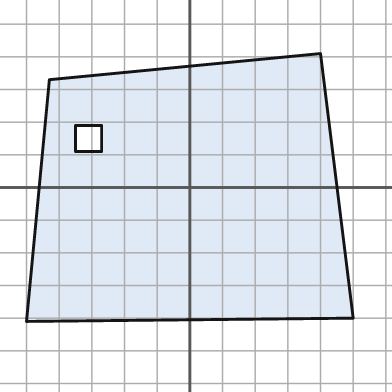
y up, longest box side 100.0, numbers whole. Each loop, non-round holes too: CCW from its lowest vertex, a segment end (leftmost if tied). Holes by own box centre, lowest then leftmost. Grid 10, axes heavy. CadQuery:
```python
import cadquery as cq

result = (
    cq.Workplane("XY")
    .moveTo(-50.0, -41.0)
    .lineTo(50.0, -40.0)
    .lineTo(40.0, 41.0)
    .lineTo(-43.0, 33.0)
    .close()
    .moveTo(-35.0, 11.0)
    .lineTo(-27.0, 11.0)
    .lineTo(-27.0, 19.0)
    .lineTo(-35.0, 19.0)
    .close()
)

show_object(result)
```